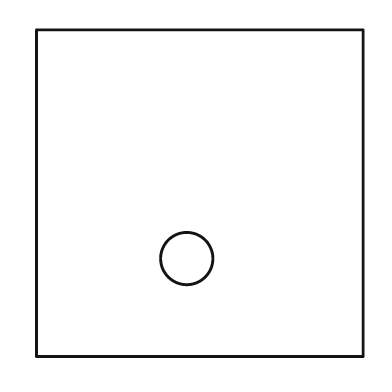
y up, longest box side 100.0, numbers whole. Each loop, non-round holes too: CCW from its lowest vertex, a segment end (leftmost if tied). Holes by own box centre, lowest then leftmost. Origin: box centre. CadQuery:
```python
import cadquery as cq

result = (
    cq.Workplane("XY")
    .moveTo(-50.0, -50.0)
    .lineTo(50.0, -50.0)
    .lineTo(50.0, 50.0)
    .lineTo(-50.0, 50.0)
    .close()
    .moveTo(-4.0, -20.0)
    .circle(8.0)
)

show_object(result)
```